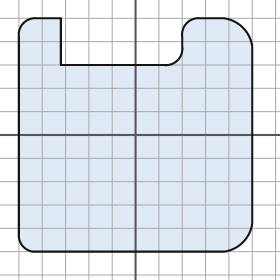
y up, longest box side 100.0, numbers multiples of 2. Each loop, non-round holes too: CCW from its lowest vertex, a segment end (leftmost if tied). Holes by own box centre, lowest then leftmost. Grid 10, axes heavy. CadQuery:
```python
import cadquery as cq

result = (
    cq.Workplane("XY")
    .moveTo(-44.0, -50.0)
    .lineTo(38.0, -50.0)
    .threePointArc((46.0, -46.0), (50.0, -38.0))
    .lineTo(50.0, 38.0)
    .threePointArc((46.0, 46.0), (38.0, 50.0))
    .lineTo(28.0, 50.0)
    .threePointArc((22.0, 48.0), (20.0, 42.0))
    .lineTo(20.0, 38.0)
    .threePointArc((18.0, 32.0), (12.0, 30.0))
    .lineTo(-32.0, 30.0)
    .lineTo(-32.0, 50.0)
    .lineTo(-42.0, 50.0)
    .threePointArc((-48.0, 48.0), (-50.0, 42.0))
    .lineTo(-50.0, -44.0)
    .threePointArc((-48.0, -48.0), (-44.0, -50.0))
    .close()
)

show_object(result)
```